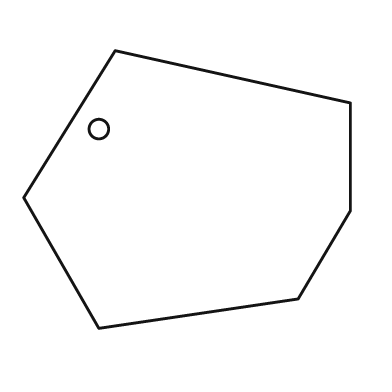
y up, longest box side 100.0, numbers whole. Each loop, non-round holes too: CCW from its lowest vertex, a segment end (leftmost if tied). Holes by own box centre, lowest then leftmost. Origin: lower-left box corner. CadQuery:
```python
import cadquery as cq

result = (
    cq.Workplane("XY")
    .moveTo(23.0, 0.0)
    .lineTo(84.0, 9.0)
    .lineTo(100.0, 36.0)
    .lineTo(100.0, 69.0)
    .lineTo(28.0, 85.0)
    .lineTo(0.0, 40.0)
    .close()
    .moveTo(23.0, 61.0)
    .circle(3.0)
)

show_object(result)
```